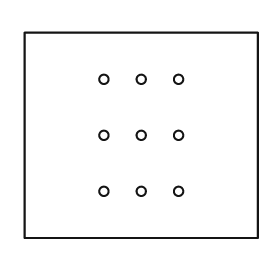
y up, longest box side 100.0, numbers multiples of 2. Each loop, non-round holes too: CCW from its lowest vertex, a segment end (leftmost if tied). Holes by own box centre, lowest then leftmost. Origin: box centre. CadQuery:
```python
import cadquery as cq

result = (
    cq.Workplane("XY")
    .moveTo(-50.0, -44.0)
    .lineTo(50.0, -44.0)
    .lineTo(50.0, 44.0)
    .lineTo(-50.0, 44.0)
    .close()
    .moveTo(-16.0, -24.0)
    .circle(2.0)
    .moveTo(0.0, -24.0)
    .circle(2.0)
    .moveTo(16.0, -24.0)
    .circle(2.0)
    .moveTo(-16.0, 0.0)
    .circle(2.0)
    .moveTo(0.0, 0.0)
    .circle(2.0)
    .moveTo(16.0, 0.0)
    .circle(2.0)
    .moveTo(-16.0, 24.0)
    .circle(2.0)
    .moveTo(0.0, 24.0)
    .circle(2.0)
    .moveTo(16.0, 24.0)
    .circle(2.0)
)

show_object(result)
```